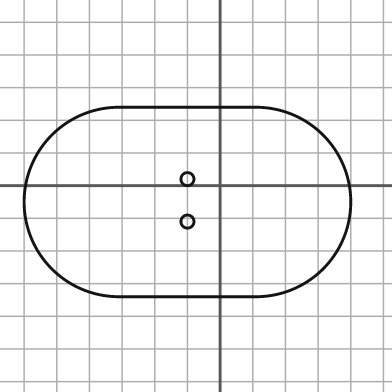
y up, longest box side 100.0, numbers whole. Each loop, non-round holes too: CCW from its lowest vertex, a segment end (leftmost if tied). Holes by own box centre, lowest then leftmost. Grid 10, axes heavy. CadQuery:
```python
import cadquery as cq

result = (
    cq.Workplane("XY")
    .moveTo(-31.0, -34.0)
    .lineTo(11.0, -34.0)
    .threePointArc((40.0, -5.0), (11.0, 24.0))
    .lineTo(-31.0, 24.0)
    .threePointArc((-60.0, -5.0), (-31.0, -34.0))
    .close()
    .moveTo(-10.0, -11.0)
    .circle(2.0)
    .moveTo(-10.0, 2.0)
    .circle(2.0)
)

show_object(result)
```